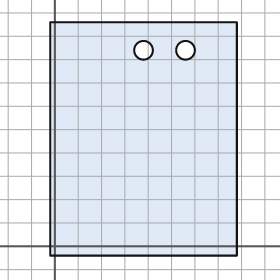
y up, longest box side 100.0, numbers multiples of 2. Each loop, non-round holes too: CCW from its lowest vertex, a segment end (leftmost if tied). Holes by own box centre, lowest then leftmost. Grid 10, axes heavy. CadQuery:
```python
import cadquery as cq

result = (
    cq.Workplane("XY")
    .moveTo(-2.0, -4.0)
    .lineTo(78.0, -4.0)
    .lineTo(78.0, 96.0)
    .lineTo(-2.0, 96.0)
    .close()
    .moveTo(38.0, 84.0)
    .circle(4.0)
    .moveTo(56.0, 84.0)
    .circle(4.0)
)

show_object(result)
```